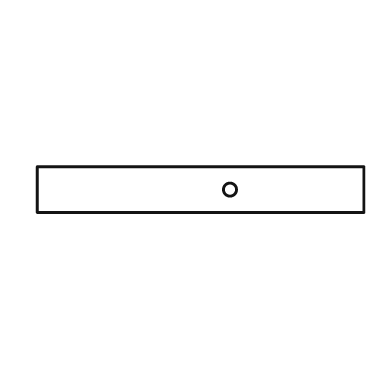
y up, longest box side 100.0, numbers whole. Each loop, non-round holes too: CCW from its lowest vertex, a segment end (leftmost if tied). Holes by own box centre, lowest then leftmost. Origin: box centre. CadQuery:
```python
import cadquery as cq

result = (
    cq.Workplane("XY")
    .moveTo(-50.0, -7.0)
    .lineTo(50.0, -7.0)
    .lineTo(50.0, 7.0)
    .lineTo(-50.0, 7.0)
    .close()
    .moveTo(9.0, 0.0)
    .circle(2.0)
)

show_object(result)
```